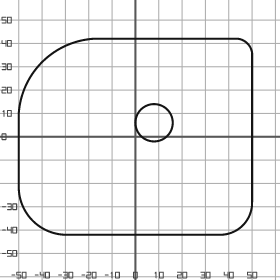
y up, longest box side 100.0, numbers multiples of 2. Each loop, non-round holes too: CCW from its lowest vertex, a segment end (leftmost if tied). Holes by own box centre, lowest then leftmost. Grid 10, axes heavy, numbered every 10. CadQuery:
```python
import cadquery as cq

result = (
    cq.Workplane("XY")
    .moveTo(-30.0, -42.0)
    .lineTo(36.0, -42.0)
    .threePointArc((46.0, -38.0), (50.0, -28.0))
    .lineTo(50.0, 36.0)
    .threePointArc((48.0, 40.0), (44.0, 42.0))
    .lineTo(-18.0, 42.0)
    .threePointArc((-40.0, 32.0), (-50.0, 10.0))
    .lineTo(-50.0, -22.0)
    .threePointArc((-44.0, -36.0), (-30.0, -42.0))
    .close()
    .moveTo(8.0, 6.0)
    .circle(8.0)
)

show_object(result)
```